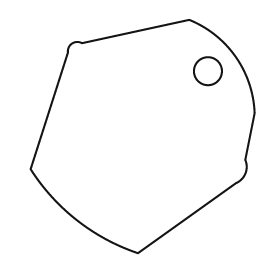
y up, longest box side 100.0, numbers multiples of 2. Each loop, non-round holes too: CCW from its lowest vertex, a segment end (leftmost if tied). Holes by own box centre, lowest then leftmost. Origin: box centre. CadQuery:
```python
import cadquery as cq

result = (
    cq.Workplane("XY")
    .moveTo(-2.0, -50.0)
    .lineTo(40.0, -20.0)
    .threePointArc((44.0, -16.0), (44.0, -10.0))
    .lineTo(48.0, 10.0)
    .threePointArc((40.0, 34.0), (20.0, 50.0))
    .lineTo(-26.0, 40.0)
    .threePointArc((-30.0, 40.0), (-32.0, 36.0))
    .lineTo(-48.0, -14.0)
    .threePointArc((-28.0, -36.0), (-2.0, -50.0))
    .close()
    .moveTo(28.0, 28.0)
    .circle(6.0)
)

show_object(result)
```